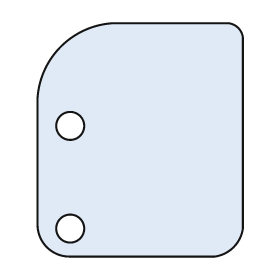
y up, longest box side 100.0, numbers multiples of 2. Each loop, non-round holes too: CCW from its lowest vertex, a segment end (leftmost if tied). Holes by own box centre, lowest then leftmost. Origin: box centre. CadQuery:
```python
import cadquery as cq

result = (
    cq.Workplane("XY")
    .moveTo(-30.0, -50.0)
    .lineTo(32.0, -50.0)
    .threePointArc((40.0, -46.0), (44.0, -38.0))
    .lineTo(44.0, 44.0)
    .threePointArc((42.0, 48.0), (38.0, 50.0))
    .lineTo(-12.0, 50.0)
    .threePointArc((-34.0, 40.0), (-44.0, 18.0))
    .lineTo(-44.0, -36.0)
    .threePointArc((-40.0, -46.0), (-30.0, -50.0))
    .close()
    .moveTo(-30.0, -38.0)
    .circle(6.0)
    .moveTo(-30.0, 6.0)
    .circle(6.0)
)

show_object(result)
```